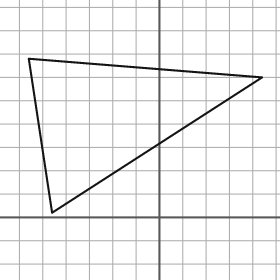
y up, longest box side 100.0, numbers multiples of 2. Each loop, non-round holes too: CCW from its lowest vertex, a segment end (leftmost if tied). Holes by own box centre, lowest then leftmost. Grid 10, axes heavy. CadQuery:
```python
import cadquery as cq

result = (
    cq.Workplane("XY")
    .moveTo(-46.0, 2.0)
    .lineTo(44.0, 60.0)
    .lineTo(-56.0, 68.0)
    .close()
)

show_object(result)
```